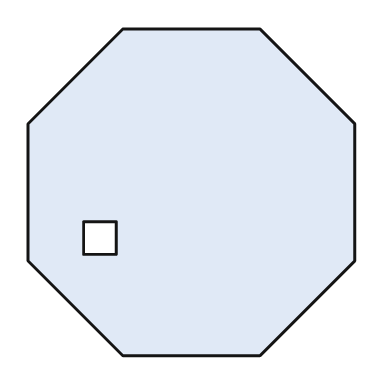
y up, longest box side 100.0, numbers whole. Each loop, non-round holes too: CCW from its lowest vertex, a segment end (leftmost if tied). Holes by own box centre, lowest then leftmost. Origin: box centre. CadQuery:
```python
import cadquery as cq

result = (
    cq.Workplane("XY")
    .moveTo(-21.0, -50.0)
    .lineTo(21.0, -50.0)
    .lineTo(50.0, -21.0)
    .lineTo(50.0, 21.0)
    .lineTo(21.0, 50.0)
    .lineTo(-21.0, 50.0)
    .lineTo(-50.0, 21.0)
    .lineTo(-50.0, -21.0)
    .close()
    .moveTo(-33.0, -19.0)
    .lineTo(-23.0, -19.0)
    .lineTo(-23.0, -9.0)
    .lineTo(-33.0, -9.0)
    .close()
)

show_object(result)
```